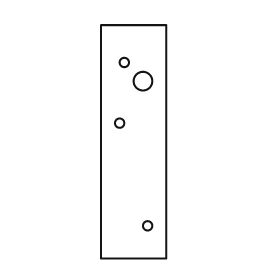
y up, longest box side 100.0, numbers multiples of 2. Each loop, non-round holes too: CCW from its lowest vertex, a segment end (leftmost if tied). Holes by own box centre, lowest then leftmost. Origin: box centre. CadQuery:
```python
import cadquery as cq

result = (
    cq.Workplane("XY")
    .moveTo(-14.0, -50.0)
    .lineTo(14.0, -50.0)
    .lineTo(14.0, 50.0)
    .lineTo(-14.0, 50.0)
    .close()
    .moveTo(6.0, -36.0)
    .circle(2.0)
    .moveTo(-6.0, 8.0)
    .circle(2.0)
    .moveTo(4.0, 26.0)
    .circle(4.0)
    .moveTo(-4.0, 34.0)
    .circle(2.0)
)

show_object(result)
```